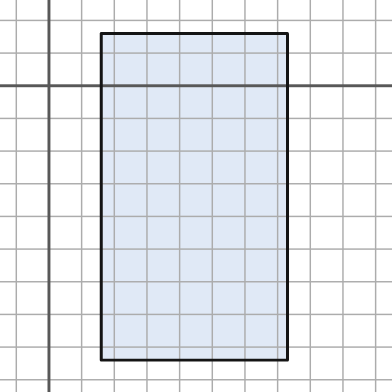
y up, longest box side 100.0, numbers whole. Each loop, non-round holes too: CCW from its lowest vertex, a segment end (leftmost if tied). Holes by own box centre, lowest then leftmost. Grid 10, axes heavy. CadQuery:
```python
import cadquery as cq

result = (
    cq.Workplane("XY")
    .moveTo(16.0, -84.0)
    .lineTo(73.0, -84.0)
    .lineTo(73.0, 16.0)
    .lineTo(16.0, 16.0)
    .close()
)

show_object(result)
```